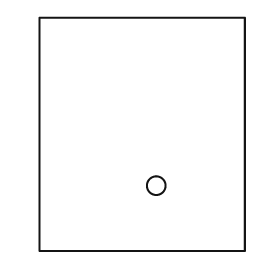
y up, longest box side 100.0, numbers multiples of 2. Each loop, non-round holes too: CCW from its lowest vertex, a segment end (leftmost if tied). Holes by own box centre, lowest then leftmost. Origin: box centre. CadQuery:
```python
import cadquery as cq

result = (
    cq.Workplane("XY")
    .moveTo(-44.0, -50.0)
    .lineTo(44.0, -50.0)
    .lineTo(44.0, 50.0)
    .lineTo(-44.0, 50.0)
    .close()
    .moveTo(6.0, -22.0)
    .circle(4.0)
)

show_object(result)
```